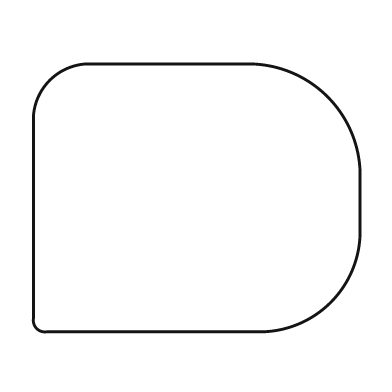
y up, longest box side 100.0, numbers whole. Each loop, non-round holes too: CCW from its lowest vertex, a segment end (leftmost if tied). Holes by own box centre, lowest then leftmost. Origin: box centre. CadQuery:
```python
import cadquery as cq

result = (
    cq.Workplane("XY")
    .moveTo(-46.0, -41.0)
    .lineTo(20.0, -41.0)
    .threePointArc((41.0, -32.0), (50.0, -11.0))
    .lineTo(50.0, 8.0)
    .threePointArc((40.0, 31.0), (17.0, 41.0))
    .lineTo(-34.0, 41.0)
    .threePointArc((-45.0, 36.0), (-50.0, 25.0))
    .lineTo(-50.0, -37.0)
    .threePointArc((-49.0, -40.0), (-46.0, -41.0))
    .close()
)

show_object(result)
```